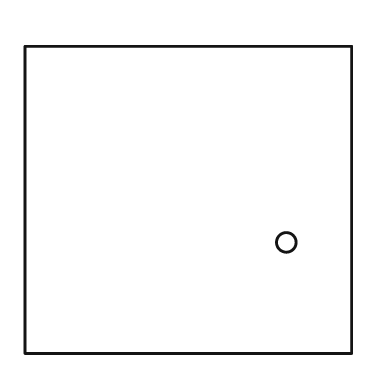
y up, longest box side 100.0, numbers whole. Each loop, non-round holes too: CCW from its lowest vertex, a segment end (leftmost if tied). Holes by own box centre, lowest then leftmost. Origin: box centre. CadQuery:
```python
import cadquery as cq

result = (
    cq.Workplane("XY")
    .moveTo(-50.0, -47.0)
    .lineTo(50.0, -47.0)
    .lineTo(50.0, 47.0)
    .lineTo(-50.0, 47.0)
    .close()
    .moveTo(30.0, -13.0)
    .circle(3.0)
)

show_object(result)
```